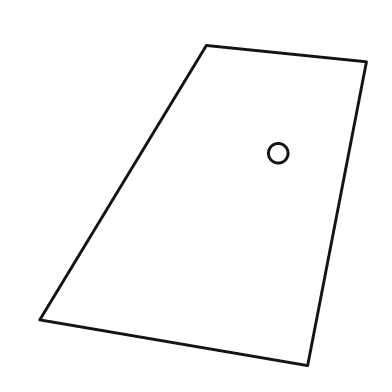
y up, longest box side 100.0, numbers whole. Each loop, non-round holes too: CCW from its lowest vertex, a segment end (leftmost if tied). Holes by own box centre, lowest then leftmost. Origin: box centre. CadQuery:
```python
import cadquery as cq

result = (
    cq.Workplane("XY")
    .moveTo(32.0, -49.0)
    .lineTo(50.0, 44.0)
    .lineTo(1.0, 49.0)
    .lineTo(-50.0, -35.0)
    .close()
    .moveTo(23.0, 16.0)
    .circle(3.0)
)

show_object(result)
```